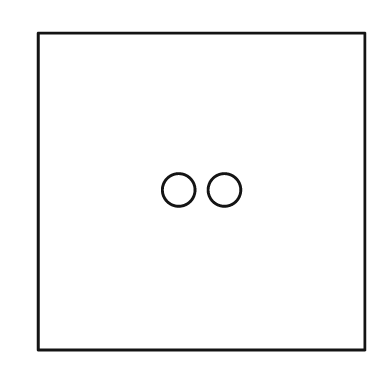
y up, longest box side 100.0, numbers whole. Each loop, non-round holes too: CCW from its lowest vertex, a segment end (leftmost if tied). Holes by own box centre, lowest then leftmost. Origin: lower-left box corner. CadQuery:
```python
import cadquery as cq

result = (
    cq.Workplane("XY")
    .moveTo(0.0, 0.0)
    .lineTo(100.0, 0.0)
    .lineTo(100.0, 97.0)
    .lineTo(0.0, 97.0)
    .close()
    .moveTo(43.0, 49.0)
    .circle(5.0)
    .moveTo(57.0, 49.0)
    .circle(5.0)
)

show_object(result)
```